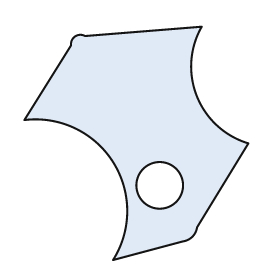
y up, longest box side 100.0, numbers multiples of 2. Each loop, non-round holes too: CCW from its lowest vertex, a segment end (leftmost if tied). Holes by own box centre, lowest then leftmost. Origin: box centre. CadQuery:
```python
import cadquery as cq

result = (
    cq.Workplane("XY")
    .moveTo(-10.0, -50.0)
    .lineTo(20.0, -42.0)
    .threePointArc((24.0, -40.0), (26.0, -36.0))
    .lineTo(48.0, 0.0)
    .threePointArc((26.0, 20.0), (28.0, 50.0))
    .lineTo(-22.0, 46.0)
    .threePointArc((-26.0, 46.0), (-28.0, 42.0))
    .lineTo(-48.0, 10.0)
    .threePointArc((-10.0, -8.0), (-10.0, -50.0))
    .close()
    .moveTo(10.0, -18.0)
    .circle(10.0)
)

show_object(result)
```